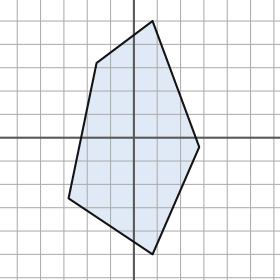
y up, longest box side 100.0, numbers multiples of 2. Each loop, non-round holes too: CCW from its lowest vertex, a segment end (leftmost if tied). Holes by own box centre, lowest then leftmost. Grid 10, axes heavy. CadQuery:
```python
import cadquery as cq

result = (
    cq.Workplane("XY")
    .moveTo(8.0, -50.0)
    .lineTo(28.0, -4.0)
    .lineTo(8.0, 50.0)
    .lineTo(-16.0, 32.0)
    .lineTo(-28.0, -26.0)
    .close()
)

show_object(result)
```